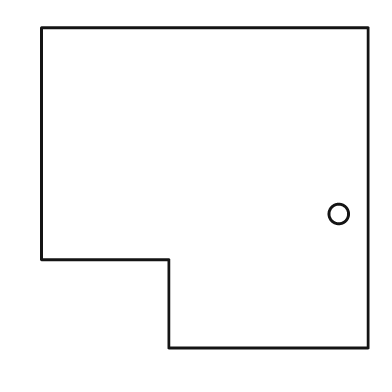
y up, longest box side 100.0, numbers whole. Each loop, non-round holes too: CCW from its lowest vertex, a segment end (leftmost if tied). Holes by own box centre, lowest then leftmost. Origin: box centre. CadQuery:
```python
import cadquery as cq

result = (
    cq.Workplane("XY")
    .moveTo(-11.0, -49.0)
    .lineTo(50.0, -49.0)
    .lineTo(50.0, 49.0)
    .lineTo(-50.0, 49.0)
    .lineTo(-50.0, -22.0)
    .lineTo(-11.0, -22.0)
    .close()
    .moveTo(41.0, -8.0)
    .circle(3.0)
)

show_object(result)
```